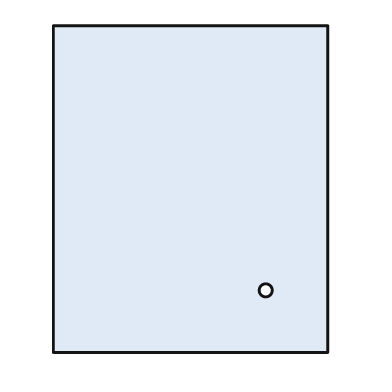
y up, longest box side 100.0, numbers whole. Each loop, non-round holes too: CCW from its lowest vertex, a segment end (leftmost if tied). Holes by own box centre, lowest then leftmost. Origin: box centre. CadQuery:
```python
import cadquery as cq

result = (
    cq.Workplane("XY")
    .moveTo(-42.0, -50.0)
    .lineTo(42.0, -50.0)
    .lineTo(42.0, 50.0)
    .lineTo(-42.0, 50.0)
    .close()
    .moveTo(23.0, -31.0)
    .circle(2.0)
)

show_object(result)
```